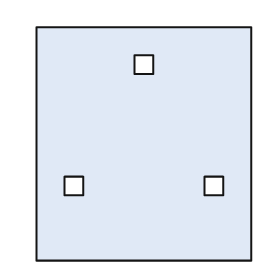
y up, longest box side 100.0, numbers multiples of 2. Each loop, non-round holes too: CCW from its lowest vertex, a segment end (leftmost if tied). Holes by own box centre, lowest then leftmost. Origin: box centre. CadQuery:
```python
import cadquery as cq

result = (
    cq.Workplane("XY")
    .moveTo(-46.0, -50.0)
    .lineTo(46.0, -50.0)
    .lineTo(46.0, 50.0)
    .lineTo(-46.0, 50.0)
    .close()
    .moveTo(-34.0, -22.0)
    .lineTo(-26.0, -22.0)
    .lineTo(-26.0, -14.0)
    .lineTo(-34.0, -14.0)
    .close()
    .moveTo(26.0, -22.0)
    .lineTo(34.0, -22.0)
    .lineTo(34.0, -14.0)
    .lineTo(26.0, -14.0)
    .close()
    .moveTo(-4.0, 30.0)
    .lineTo(4.0, 30.0)
    .lineTo(4.0, 38.0)
    .lineTo(-4.0, 38.0)
    .close()
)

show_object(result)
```